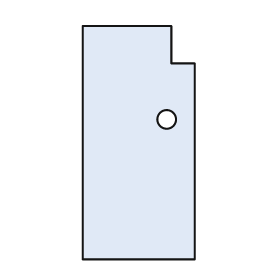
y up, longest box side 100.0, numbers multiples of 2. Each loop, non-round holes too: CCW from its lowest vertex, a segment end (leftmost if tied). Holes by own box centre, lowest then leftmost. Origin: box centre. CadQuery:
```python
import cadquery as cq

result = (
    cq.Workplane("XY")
    .moveTo(-24.0, -50.0)
    .lineTo(24.0, -50.0)
    .lineTo(24.0, 34.0)
    .lineTo(14.0, 34.0)
    .lineTo(14.0, 50.0)
    .lineTo(-24.0, 50.0)
    .close()
    .moveTo(12.0, 10.0)
    .circle(4.0)
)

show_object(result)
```